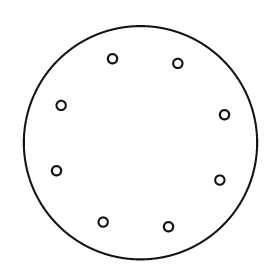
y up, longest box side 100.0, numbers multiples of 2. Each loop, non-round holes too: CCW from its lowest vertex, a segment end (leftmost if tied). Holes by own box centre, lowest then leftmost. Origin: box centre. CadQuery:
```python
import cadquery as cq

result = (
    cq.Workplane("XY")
    .moveTo(0.0, 0.0)
    .circle(50.0)
    .moveTo(12.0, -36.0)
    .circle(2.0)
    .moveTo(-16.0, -34.0)
    .circle(2.0)
    .moveTo(34.0, -16.0)
    .circle(2.0)
    .moveTo(-36.0, -12.0)
    .circle(2.0)
    .moveTo(36.0, 12.0)
    .circle(2.0)
    .moveTo(-34.0, 16.0)
    .circle(2.0)
    .moveTo(16.0, 34.0)
    .circle(2.0)
    .moveTo(-12.0, 36.0)
    .circle(2.0)
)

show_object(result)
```